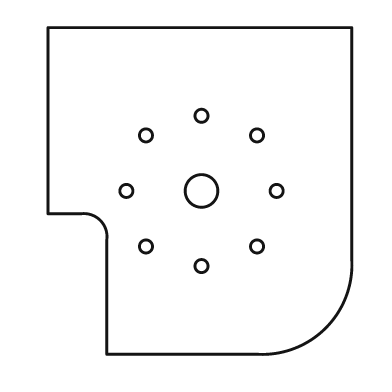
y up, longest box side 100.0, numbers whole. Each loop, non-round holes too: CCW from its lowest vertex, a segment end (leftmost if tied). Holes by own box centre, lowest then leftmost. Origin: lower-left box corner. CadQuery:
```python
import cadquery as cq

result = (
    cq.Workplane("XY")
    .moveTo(18.0, 0.0)
    .lineTo(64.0, 0.0)
    .threePointArc((85.0, 8.0), (93.0, 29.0))
    .lineTo(93.0, 100.0)
    .lineTo(0.0, 100.0)
    .lineTo(0.0, 43.0)
    .lineTo(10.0, 43.0)
    .threePointArc((16.0, 41.0), (18.0, 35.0))
    .close()
    .moveTo(47.0, 27.0)
    .circle(2.0)
    .moveTo(30.0, 33.0)
    .circle(2.0)
    .moveTo(64.0, 33.0)
    .circle(2.0)
    .moveTo(24.0, 50.0)
    .circle(2.0)
    .moveTo(47.0, 50.0)
    .circle(5.0)
    .moveTo(70.0, 50.0)
    .circle(2.0)
    .moveTo(30.0, 67.0)
    .circle(2.0)
    .moveTo(64.0, 67.0)
    .circle(2.0)
    .moveTo(47.0, 73.0)
    .circle(2.0)
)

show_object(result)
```